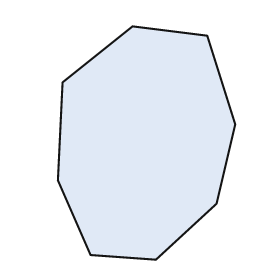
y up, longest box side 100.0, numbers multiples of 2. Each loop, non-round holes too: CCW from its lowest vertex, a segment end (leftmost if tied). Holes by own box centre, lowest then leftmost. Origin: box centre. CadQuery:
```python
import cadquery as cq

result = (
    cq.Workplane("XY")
    .moveTo(4.0, -50.0)
    .lineTo(30.0, -26.0)
    .lineTo(38.0, 8.0)
    .lineTo(26.0, 46.0)
    .lineTo(-6.0, 50.0)
    .lineTo(-36.0, 26.0)
    .lineTo(-38.0, -16.0)
    .lineTo(-24.0, -48.0)
    .close()
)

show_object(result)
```